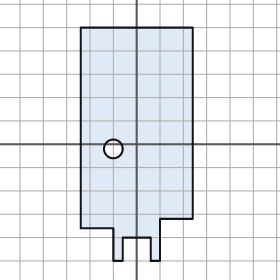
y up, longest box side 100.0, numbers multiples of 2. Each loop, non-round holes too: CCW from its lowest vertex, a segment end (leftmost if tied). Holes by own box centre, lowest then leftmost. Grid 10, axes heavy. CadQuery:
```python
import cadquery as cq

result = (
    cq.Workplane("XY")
    .moveTo(-10.0, -50.0)
    .lineTo(-6.0, -50.0)
    .lineTo(-6.0, -40.0)
    .lineTo(6.0, -40.0)
    .lineTo(6.0, -50.0)
    .lineTo(10.0, -50.0)
    .lineTo(10.0, -32.0)
    .lineTo(24.0, -32.0)
    .lineTo(24.0, 50.0)
    .lineTo(-24.0, 50.0)
    .lineTo(-24.0, -36.0)
    .lineTo(-10.0, -36.0)
    .close()
    .moveTo(-10.0, -2.0)
    .circle(4.0)
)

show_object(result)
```